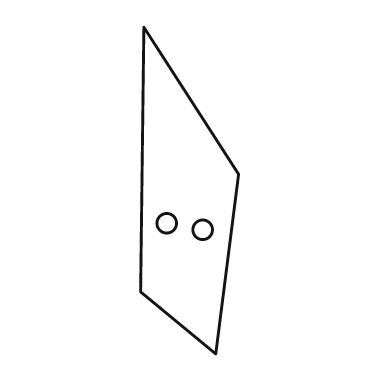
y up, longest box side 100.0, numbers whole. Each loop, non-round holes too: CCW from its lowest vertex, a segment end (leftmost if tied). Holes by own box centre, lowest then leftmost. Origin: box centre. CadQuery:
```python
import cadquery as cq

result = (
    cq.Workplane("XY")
    .moveTo(8.0, -50.0)
    .lineTo(15.0, 5.0)
    .lineTo(-14.0, 50.0)
    .lineTo(-15.0, -31.0)
    .close()
    .moveTo(4.0, -12.0)
    .circle(3.0)
    .moveTo(-7.0, -10.0)
    .circle(3.0)
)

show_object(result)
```